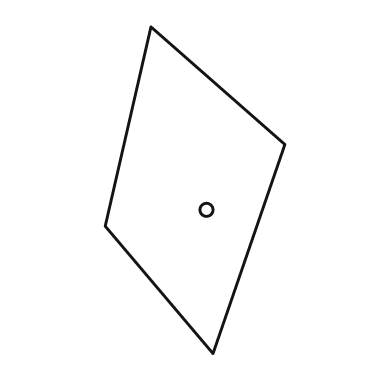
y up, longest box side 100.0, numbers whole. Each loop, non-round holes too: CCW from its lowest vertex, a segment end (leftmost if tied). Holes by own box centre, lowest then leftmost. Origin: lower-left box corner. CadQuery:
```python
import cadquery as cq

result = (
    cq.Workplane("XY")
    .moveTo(33.0, 0.0)
    .lineTo(55.0, 64.0)
    .lineTo(14.0, 100.0)
    .lineTo(0.0, 39.0)
    .close()
    .moveTo(31.0, 44.0)
    .circle(2.0)
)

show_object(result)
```